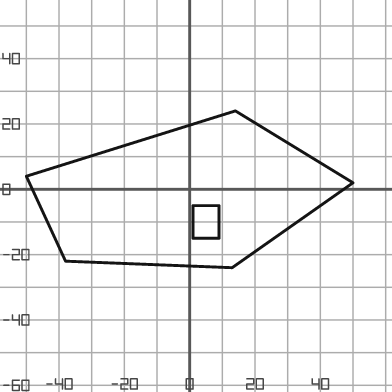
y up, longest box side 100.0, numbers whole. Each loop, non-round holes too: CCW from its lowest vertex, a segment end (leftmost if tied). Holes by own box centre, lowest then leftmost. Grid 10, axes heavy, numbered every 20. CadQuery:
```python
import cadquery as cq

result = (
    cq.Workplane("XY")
    .moveTo(13.0, -24.0)
    .lineTo(50.0, 2.0)
    .lineTo(14.0, 24.0)
    .lineTo(-50.0, 4.0)
    .lineTo(-38.0, -22.0)
    .close()
    .moveTo(1.0, -15.0)
    .lineTo(9.0, -15.0)
    .lineTo(9.0, -5.0)
    .lineTo(1.0, -5.0)
    .close()
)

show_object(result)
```